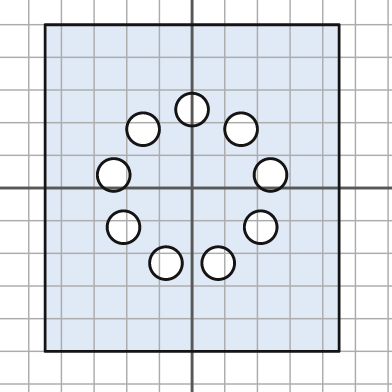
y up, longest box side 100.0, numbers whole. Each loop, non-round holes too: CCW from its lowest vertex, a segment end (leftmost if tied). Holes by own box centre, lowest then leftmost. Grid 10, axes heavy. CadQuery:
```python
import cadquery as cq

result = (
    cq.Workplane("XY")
    .moveTo(-45.0, -50.0)
    .lineTo(45.0, -50.0)
    .lineTo(45.0, 50.0)
    .lineTo(-45.0, 50.0)
    .close()
    .moveTo(-8.0, -23.0)
    .circle(5.0)
    .moveTo(8.0, -23.0)
    .circle(5.0)
    .moveTo(-21.0, -12.0)
    .circle(5.0)
    .moveTo(21.0, -12.0)
    .circle(5.0)
    .moveTo(-24.0, 4.0)
    .circle(5.0)
    .moveTo(24.0, 4.0)
    .circle(5.0)
    .moveTo(-15.0, 18.0)
    .circle(5.0)
    .moveTo(15.0, 18.0)
    .circle(5.0)
    .moveTo(0.0, 24.0)
    .circle(5.0)
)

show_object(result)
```